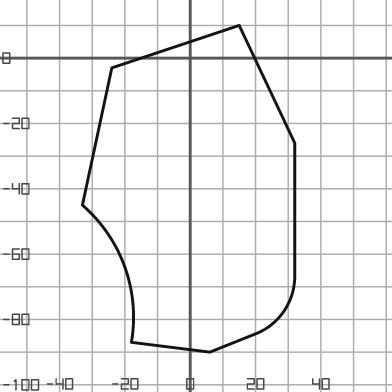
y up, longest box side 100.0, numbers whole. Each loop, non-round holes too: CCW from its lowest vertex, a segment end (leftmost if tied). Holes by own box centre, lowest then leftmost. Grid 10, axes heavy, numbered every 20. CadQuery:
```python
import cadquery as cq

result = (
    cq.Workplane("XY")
    .moveTo(6.0, -90.0)
    .lineTo(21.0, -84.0)
    .threePointArc((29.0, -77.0), (32.0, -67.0))
    .lineTo(32.0, -26.0)
    .lineTo(15.0, 10.0)
    .lineTo(-24.0, -3.0)
    .lineTo(-33.0, -45.0)
    .threePointArc((-20.0, -64.0), (-18.0, -87.0))
    .close()
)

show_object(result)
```